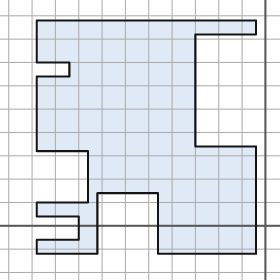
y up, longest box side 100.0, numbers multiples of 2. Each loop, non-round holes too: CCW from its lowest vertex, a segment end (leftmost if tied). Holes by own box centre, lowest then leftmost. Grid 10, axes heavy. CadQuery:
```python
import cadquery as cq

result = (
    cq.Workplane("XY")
    .moveTo(-98.0, -12.0)
    .lineTo(-72.0, -12.0)
    .lineTo(-72.0, 14.0)
    .lineTo(-46.0, 14.0)
    .lineTo(-46.0, -12.0)
    .lineTo(-4.0, -12.0)
    .lineTo(-4.0, 34.0)
    .lineTo(-30.0, 34.0)
    .lineTo(-30.0, 82.0)
    .lineTo(-4.0, 82.0)
    .lineTo(-4.0, 88.0)
    .lineTo(-98.0, 88.0)
    .lineTo(-98.0, 70.0)
    .lineTo(-84.0, 70.0)
    .lineTo(-84.0, 64.0)
    .lineTo(-98.0, 64.0)
    .lineTo(-98.0, 32.0)
    .lineTo(-76.0, 32.0)
    .lineTo(-76.0, 10.0)
    .lineTo(-98.0, 10.0)
    .lineTo(-98.0, 4.0)
    .lineTo(-80.0, 4.0)
    .lineTo(-80.0, -6.0)
    .lineTo(-98.0, -6.0)
    .close()
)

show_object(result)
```